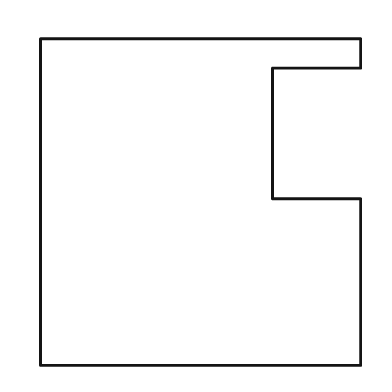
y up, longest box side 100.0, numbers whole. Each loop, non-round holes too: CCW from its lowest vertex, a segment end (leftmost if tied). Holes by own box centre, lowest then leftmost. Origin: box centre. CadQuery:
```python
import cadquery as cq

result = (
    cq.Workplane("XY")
    .moveTo(-49.0, -50.0)
    .lineTo(49.0, -50.0)
    .lineTo(49.0, 1.0)
    .lineTo(22.0, 1.0)
    .lineTo(22.0, 41.0)
    .lineTo(49.0, 41.0)
    .lineTo(49.0, 50.0)
    .lineTo(-49.0, 50.0)
    .close()
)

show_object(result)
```